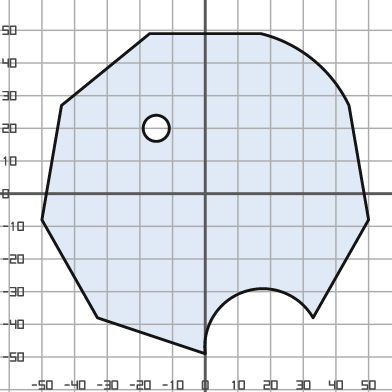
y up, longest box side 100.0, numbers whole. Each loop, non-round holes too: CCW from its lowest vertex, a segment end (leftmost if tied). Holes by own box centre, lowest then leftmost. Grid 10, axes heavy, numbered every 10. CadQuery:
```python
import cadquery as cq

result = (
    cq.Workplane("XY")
    .moveTo(0.0, -49.0)
    .threePointArc((12.0, -30.0), (33.0, -38.0))
    .lineTo(50.0, -8.0)
    .lineTo(44.0, 27.0)
    .threePointArc((33.0, 41.0), (17.0, 49.0))
    .lineTo(-17.0, 49.0)
    .lineTo(-44.0, 27.0)
    .lineTo(-50.0, -8.0)
    .lineTo(-33.0, -38.0)
    .close()
    .moveTo(-15.0, 20.0)
    .circle(4.0)
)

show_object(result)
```